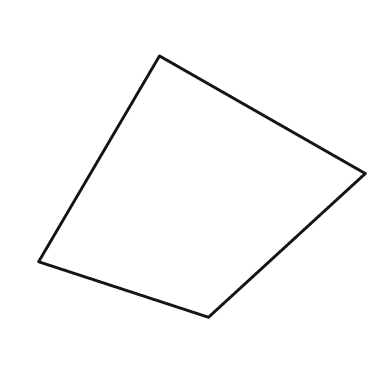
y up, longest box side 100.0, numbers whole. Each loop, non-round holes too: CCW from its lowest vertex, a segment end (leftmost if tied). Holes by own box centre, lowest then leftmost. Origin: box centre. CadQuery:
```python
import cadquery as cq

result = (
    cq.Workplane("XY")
    .moveTo(2.0, -40.0)
    .lineTo(50.0, 4.0)
    .lineTo(-13.0, 40.0)
    .lineTo(-50.0, -23.0)
    .close()
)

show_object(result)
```